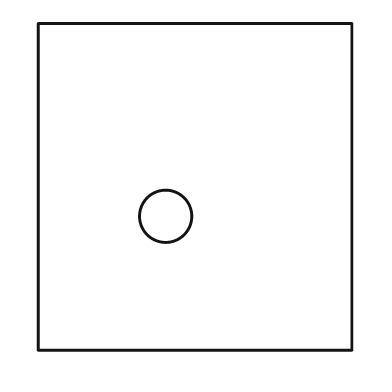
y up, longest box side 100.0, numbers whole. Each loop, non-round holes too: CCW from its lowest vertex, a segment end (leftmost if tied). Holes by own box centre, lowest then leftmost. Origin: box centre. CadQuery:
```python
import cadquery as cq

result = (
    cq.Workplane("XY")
    .moveTo(-48.0, -50.0)
    .lineTo(48.0, -50.0)
    .lineTo(48.0, 50.0)
    .lineTo(-48.0, 50.0)
    .close()
    .moveTo(-9.0, -9.0)
    .circle(8.0)
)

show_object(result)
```